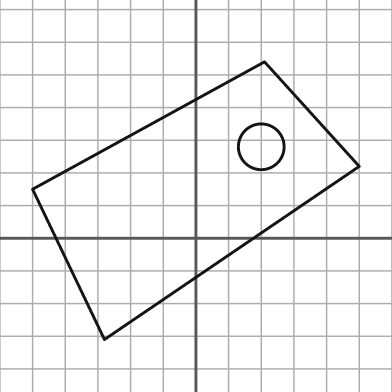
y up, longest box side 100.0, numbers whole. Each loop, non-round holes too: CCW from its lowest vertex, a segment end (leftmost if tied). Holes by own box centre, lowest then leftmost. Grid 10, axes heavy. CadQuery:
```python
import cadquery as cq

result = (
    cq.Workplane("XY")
    .moveTo(-28.0, -31.0)
    .lineTo(50.0, 22.0)
    .lineTo(21.0, 54.0)
    .lineTo(-50.0, 15.0)
    .close()
    .moveTo(20.0, 28.0)
    .circle(7.0)
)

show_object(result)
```